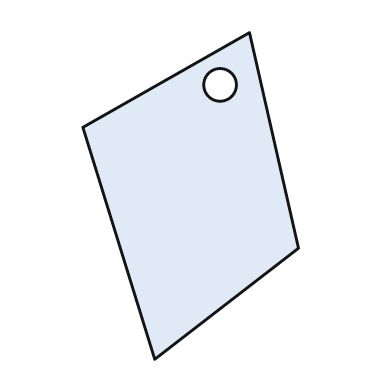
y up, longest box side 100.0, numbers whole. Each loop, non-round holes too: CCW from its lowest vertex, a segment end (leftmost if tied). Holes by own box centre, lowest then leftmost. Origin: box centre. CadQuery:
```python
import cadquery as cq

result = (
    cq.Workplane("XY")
    .moveTo(-11.0, -50.0)
    .lineTo(33.0, -16.0)
    .lineTo(18.0, 50.0)
    .lineTo(-33.0, 21.0)
    .close()
    .moveTo(9.0, 34.0)
    .circle(5.0)
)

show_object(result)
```